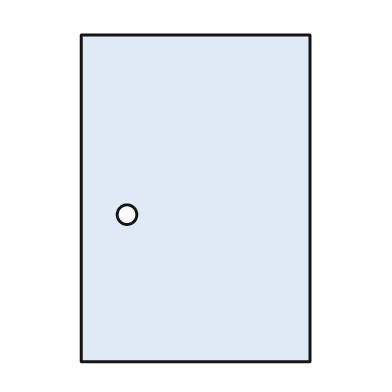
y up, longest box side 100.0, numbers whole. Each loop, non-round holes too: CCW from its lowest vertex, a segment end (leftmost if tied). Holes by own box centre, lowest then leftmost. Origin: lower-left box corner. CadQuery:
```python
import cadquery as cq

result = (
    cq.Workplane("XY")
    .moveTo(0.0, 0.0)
    .lineTo(70.0, 0.0)
    .lineTo(70.0, 100.0)
    .lineTo(0.0, 100.0)
    .close()
    .moveTo(14.0, 45.0)
    .circle(3.0)
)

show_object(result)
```